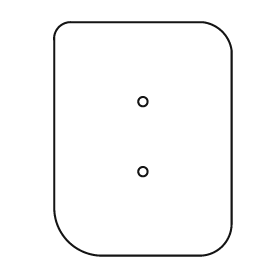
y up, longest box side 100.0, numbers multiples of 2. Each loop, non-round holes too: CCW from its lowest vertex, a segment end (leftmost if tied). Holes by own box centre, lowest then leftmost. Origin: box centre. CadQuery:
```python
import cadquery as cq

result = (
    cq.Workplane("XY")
    .moveTo(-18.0, -50.0)
    .lineTo(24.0, -50.0)
    .threePointArc((34.0, -46.0), (38.0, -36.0))
    .lineTo(38.0, 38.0)
    .threePointArc((34.0, 46.0), (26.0, 50.0))
    .lineTo(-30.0, 50.0)
    .threePointArc((-36.0, 48.0), (-38.0, 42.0))
    .lineTo(-38.0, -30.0)
    .threePointArc((-32.0, -44.0), (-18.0, -50.0))
    .close()
    .moveTo(0.0, -14.0)
    .circle(2.0)
    .moveTo(0.0, 16.0)
    .circle(2.0)
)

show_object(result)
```